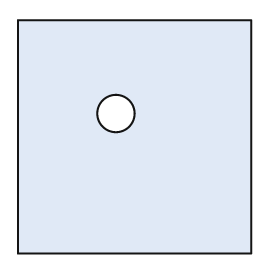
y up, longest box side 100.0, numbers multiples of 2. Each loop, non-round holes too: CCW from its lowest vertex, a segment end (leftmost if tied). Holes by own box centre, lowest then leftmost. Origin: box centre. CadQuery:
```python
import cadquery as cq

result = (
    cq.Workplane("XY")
    .moveTo(-50.0, -50.0)
    .lineTo(50.0, -50.0)
    .lineTo(50.0, 50.0)
    .lineTo(-50.0, 50.0)
    .close()
    .moveTo(-8.0, 10.0)
    .circle(8.0)
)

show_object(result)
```